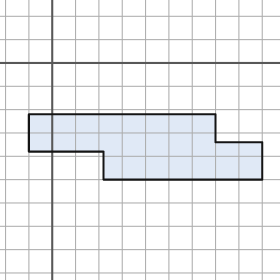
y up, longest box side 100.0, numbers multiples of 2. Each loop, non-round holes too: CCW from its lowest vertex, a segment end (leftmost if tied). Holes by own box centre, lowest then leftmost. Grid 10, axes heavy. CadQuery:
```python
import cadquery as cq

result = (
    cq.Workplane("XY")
    .moveTo(22.0, -50.0)
    .lineTo(90.0, -50.0)
    .lineTo(90.0, -34.0)
    .lineTo(70.0, -34.0)
    .lineTo(70.0, -22.0)
    .lineTo(-10.0, -22.0)
    .lineTo(-10.0, -38.0)
    .lineTo(22.0, -38.0)
    .close()
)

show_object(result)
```